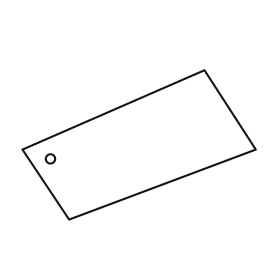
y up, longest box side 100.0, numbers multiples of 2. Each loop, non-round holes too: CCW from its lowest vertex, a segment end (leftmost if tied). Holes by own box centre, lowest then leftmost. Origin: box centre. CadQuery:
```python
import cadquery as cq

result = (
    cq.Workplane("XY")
    .moveTo(-30.0, -32.0)
    .lineTo(50.0, -2.0)
    .lineTo(28.0, 32.0)
    .lineTo(-50.0, -2.0)
    .close()
    .moveTo(-38.0, -6.0)
    .circle(2.0)
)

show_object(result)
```